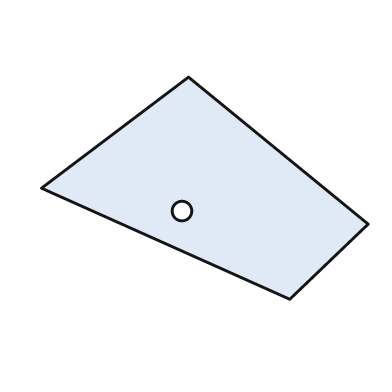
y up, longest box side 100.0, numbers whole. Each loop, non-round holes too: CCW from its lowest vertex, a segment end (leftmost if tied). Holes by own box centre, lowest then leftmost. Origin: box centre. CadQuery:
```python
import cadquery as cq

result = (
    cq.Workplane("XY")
    .moveTo(26.0, -34.0)
    .lineTo(50.0, -11.0)
    .lineTo(-5.0, 34.0)
    .lineTo(-50.0, 0.0)
    .close()
    .moveTo(-7.0, -7.0)
    .circle(3.0)
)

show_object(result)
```